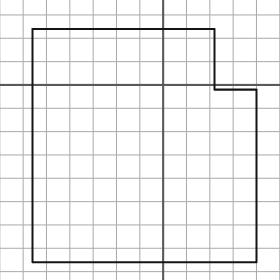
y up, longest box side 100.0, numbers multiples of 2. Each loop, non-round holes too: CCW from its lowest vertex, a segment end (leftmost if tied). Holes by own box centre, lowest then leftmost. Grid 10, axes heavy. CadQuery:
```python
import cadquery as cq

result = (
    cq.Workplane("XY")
    .moveTo(-56.0, -76.0)
    .lineTo(40.0, -76.0)
    .lineTo(40.0, -2.0)
    .lineTo(22.0, -2.0)
    .lineTo(22.0, 24.0)
    .lineTo(-56.0, 24.0)
    .close()
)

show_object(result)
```